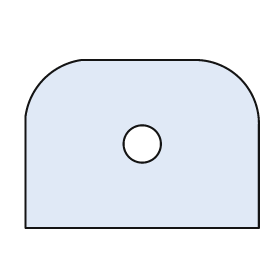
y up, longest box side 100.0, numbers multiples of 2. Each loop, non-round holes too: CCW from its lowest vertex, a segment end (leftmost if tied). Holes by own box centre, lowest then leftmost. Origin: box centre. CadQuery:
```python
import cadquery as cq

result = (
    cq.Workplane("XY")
    .moveTo(-50.0, -36.0)
    .lineTo(50.0, -36.0)
    .lineTo(50.0, 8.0)
    .threePointArc((42.0, 28.0), (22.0, 36.0))
    .lineTo(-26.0, 36.0)
    .threePointArc((-42.0, 28.0), (-50.0, 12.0))
    .close()
    .moveTo(0.0, 0.0)
    .circle(8.0)
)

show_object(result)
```